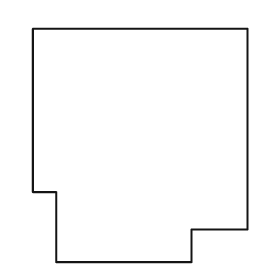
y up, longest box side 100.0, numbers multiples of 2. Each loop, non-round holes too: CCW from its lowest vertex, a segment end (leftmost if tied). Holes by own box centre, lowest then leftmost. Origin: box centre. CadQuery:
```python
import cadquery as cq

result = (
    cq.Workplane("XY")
    .moveTo(-36.0, -50.0)
    .lineTo(22.0, -50.0)
    .lineTo(22.0, -36.0)
    .lineTo(46.0, -36.0)
    .lineTo(46.0, 50.0)
    .lineTo(-46.0, 50.0)
    .lineTo(-46.0, -20.0)
    .lineTo(-36.0, -20.0)
    .close()
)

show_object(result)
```